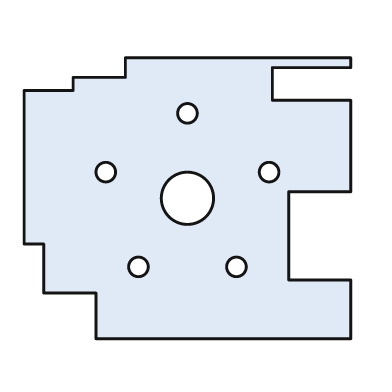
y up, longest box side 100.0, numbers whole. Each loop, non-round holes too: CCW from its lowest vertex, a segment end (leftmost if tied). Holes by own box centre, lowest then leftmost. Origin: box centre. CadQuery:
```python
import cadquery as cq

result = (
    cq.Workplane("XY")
    .moveTo(-28.0, -43.0)
    .lineTo(50.0, -43.0)
    .lineTo(50.0, -25.0)
    .lineTo(31.0, -25.0)
    .lineTo(31.0, 2.0)
    .lineTo(50.0, 2.0)
    .lineTo(50.0, 30.0)
    .lineTo(26.0, 30.0)
    .lineTo(26.0, 40.0)
    .lineTo(50.0, 40.0)
    .lineTo(50.0, 43.0)
    .lineTo(-19.0, 43.0)
    .lineTo(-19.0, 37.0)
    .lineTo(-35.0, 37.0)
    .lineTo(-35.0, 33.0)
    .lineTo(-50.0, 33.0)
    .lineTo(-50.0, -14.0)
    .lineTo(-44.0, -14.0)
    .lineTo(-44.0, -29.0)
    .lineTo(-28.0, -29.0)
    .close()
    .moveTo(-15.0, -21.0)
    .circle(3.0)
    .moveTo(15.0, -21.0)
    .circle(3.0)
    .moveTo(0.0, 0.0)
    .circle(8.0)
    .moveTo(-25.0, 8.0)
    .circle(3.0)
    .moveTo(25.0, 8.0)
    .circle(3.0)
    .moveTo(0.0, 26.0)
    .circle(3.0)
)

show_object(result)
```